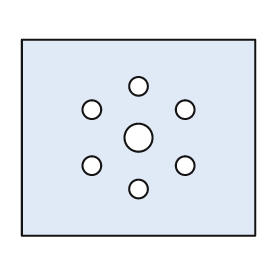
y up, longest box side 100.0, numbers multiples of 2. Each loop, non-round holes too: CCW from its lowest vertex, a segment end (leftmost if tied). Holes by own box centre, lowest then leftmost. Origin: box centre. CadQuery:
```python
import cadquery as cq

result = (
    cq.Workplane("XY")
    .moveTo(-50.0, -42.0)
    .lineTo(50.0, -42.0)
    .lineTo(50.0, 42.0)
    .lineTo(-50.0, 42.0)
    .close()
    .moveTo(0.0, -22.0)
    .circle(4.0)
    .moveTo(-20.0, -12.0)
    .circle(4.0)
    .moveTo(20.0, -12.0)
    .circle(4.0)
    .moveTo(0.0, 0.0)
    .circle(6.0)
    .moveTo(-20.0, 12.0)
    .circle(4.0)
    .moveTo(20.0, 12.0)
    .circle(4.0)
    .moveTo(0.0, 22.0)
    .circle(4.0)
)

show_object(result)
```